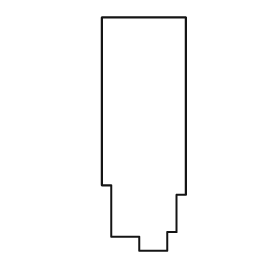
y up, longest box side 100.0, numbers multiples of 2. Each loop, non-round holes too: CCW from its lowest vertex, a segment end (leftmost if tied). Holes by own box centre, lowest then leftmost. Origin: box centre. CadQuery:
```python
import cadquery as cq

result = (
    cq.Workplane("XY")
    .moveTo(-2.0, -50.0)
    .lineTo(10.0, -50.0)
    .lineTo(10.0, -42.0)
    .lineTo(14.0, -42.0)
    .lineTo(14.0, -26.0)
    .lineTo(18.0, -26.0)
    .lineTo(18.0, 50.0)
    .lineTo(-18.0, 50.0)
    .lineTo(-18.0, -22.0)
    .lineTo(-14.0, -22.0)
    .lineTo(-14.0, -44.0)
    .lineTo(-2.0, -44.0)
    .close()
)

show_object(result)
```